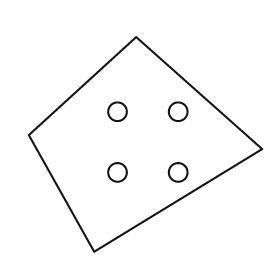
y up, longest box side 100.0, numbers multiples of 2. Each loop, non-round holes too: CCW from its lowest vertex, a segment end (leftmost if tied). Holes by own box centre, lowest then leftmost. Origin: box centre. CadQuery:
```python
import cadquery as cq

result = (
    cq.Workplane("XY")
    .moveTo(-22.0, -46.0)
    .lineTo(50.0, -2.0)
    .lineTo(-4.0, 46.0)
    .lineTo(-50.0, 4.0)
    .close()
    .moveTo(-12.0, -12.0)
    .circle(4.0)
    .moveTo(14.0, -12.0)
    .circle(4.0)
    .moveTo(-12.0, 14.0)
    .circle(4.0)
    .moveTo(14.0, 14.0)
    .circle(4.0)
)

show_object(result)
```